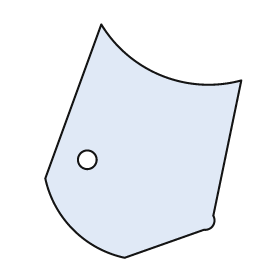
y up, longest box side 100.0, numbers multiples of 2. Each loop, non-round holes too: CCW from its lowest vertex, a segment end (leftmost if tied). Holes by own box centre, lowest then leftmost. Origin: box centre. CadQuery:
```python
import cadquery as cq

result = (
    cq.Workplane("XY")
    .moveTo(-8.0, -50.0)
    .lineTo(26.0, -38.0)
    .threePointArc((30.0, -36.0), (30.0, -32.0))
    .lineTo(42.0, 26.0)
    .threePointArc((8.0, 28.0), (-18.0, 50.0))
    .lineTo(-42.0, -16.0)
    .threePointArc((-30.0, -38.0), (-8.0, -50.0))
    .close()
    .moveTo(-24.0, -8.0)
    .circle(4.0)
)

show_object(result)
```